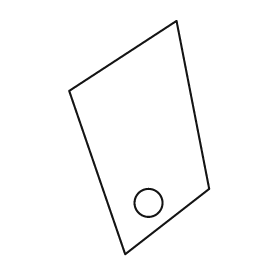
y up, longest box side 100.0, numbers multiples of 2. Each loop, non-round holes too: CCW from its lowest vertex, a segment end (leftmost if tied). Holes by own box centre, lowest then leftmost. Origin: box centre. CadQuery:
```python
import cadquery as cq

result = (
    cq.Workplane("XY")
    .moveTo(-6.0, -50.0)
    .lineTo(30.0, -22.0)
    .lineTo(16.0, 50.0)
    .lineTo(-30.0, 20.0)
    .close()
    .moveTo(4.0, -28.0)
    .circle(6.0)
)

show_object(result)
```